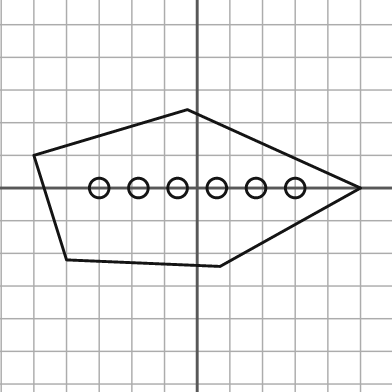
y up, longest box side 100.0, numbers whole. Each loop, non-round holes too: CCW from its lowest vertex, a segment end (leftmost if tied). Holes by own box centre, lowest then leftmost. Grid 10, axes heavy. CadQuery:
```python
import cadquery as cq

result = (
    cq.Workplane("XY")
    .moveTo(7.0, -24.0)
    .lineTo(50.0, 0.0)
    .lineTo(-3.0, 24.0)
    .lineTo(-50.0, 10.0)
    .lineTo(-40.0, -22.0)
    .close()
    .moveTo(-30.0, 0.0)
    .circle(3.0)
    .moveTo(-18.0, 0.0)
    .circle(3.0)
    .moveTo(-6.0, 0.0)
    .circle(3.0)
    .moveTo(6.0, 0.0)
    .circle(3.0)
    .moveTo(18.0, 0.0)
    .circle(3.0)
    .moveTo(30.0, 0.0)
    .circle(3.0)
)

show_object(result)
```